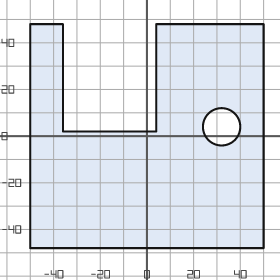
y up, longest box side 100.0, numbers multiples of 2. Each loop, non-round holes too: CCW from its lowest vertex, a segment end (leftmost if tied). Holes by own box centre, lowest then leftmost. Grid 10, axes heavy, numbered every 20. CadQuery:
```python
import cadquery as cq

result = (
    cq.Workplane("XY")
    .moveTo(-50.0, -48.0)
    .lineTo(50.0, -48.0)
    .lineTo(50.0, 48.0)
    .lineTo(4.0, 48.0)
    .lineTo(4.0, 2.0)
    .lineTo(-36.0, 2.0)
    .lineTo(-36.0, 48.0)
    .lineTo(-50.0, 48.0)
    .close()
    .moveTo(32.0, 4.0)
    .circle(8.0)
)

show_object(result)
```